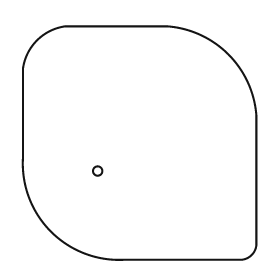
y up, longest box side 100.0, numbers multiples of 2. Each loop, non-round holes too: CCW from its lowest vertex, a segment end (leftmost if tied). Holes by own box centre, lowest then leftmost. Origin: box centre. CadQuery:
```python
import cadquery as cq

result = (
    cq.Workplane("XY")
    .moveTo(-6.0, -50.0)
    .lineTo(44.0, -50.0)
    .threePointArc((48.0, -48.0), (50.0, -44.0))
    .lineTo(50.0, 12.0)
    .threePointArc((38.0, 38.0), (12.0, 50.0))
    .lineTo(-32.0, 50.0)
    .threePointArc((-44.0, 44.0), (-50.0, 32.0))
    .lineTo(-50.0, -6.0)
    .threePointArc((-38.0, -38.0), (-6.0, -50.0))
    .close()
    .moveTo(-18.0, -12.0)
    .circle(2.0)
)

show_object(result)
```